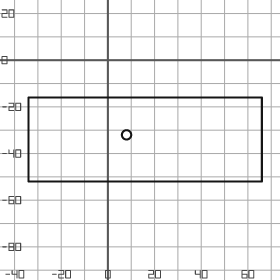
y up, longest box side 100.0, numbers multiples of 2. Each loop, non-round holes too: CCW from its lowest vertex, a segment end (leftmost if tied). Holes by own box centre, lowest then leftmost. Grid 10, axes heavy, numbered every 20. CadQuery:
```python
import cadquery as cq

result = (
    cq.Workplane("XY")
    .moveTo(-34.0, -52.0)
    .lineTo(66.0, -52.0)
    .lineTo(66.0, -16.0)
    .lineTo(-34.0, -16.0)
    .close()
    .moveTo(8.0, -32.0)
    .circle(2.0)
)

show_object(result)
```